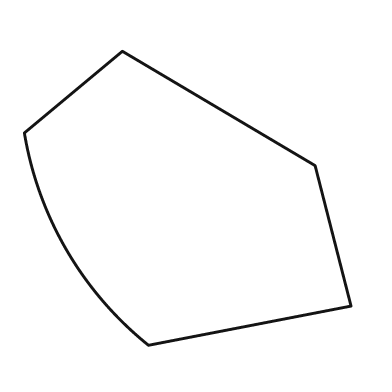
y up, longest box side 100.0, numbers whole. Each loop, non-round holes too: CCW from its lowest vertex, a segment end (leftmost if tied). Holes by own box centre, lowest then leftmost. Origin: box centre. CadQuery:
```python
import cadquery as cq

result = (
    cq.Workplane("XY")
    .moveTo(-12.0, -45.0)
    .lineTo(50.0, -33.0)
    .lineTo(39.0, 10.0)
    .lineTo(-20.0, 45.0)
    .lineTo(-50.0, 20.0)
    .threePointArc((-37.0, -16.0), (-12.0, -45.0))
    .close()
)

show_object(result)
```